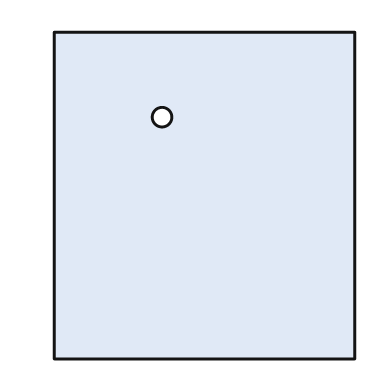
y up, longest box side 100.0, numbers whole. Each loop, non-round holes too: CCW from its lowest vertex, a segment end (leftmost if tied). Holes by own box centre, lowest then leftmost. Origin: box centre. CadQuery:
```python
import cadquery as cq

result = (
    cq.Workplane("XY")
    .moveTo(-46.0, -50.0)
    .lineTo(46.0, -50.0)
    .lineTo(46.0, 50.0)
    .lineTo(-46.0, 50.0)
    .close()
    .moveTo(-13.0, 24.0)
    .circle(3.0)
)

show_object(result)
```